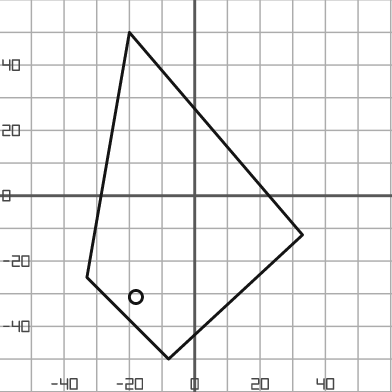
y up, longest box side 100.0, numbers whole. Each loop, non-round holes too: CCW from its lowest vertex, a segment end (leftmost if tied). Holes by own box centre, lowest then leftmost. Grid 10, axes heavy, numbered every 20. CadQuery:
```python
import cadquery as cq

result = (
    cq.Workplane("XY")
    .moveTo(-8.0, -50.0)
    .lineTo(33.0, -12.0)
    .lineTo(-20.0, 50.0)
    .lineTo(-33.0, -25.0)
    .close()
    .moveTo(-18.0, -31.0)
    .circle(2.0)
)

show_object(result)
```